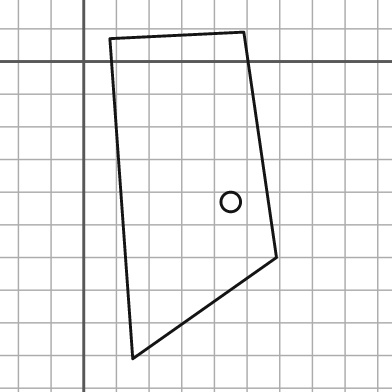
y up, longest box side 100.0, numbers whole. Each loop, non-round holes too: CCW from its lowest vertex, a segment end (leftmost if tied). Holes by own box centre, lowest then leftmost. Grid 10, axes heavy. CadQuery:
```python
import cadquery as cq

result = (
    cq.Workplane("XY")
    .moveTo(15.0, -91.0)
    .lineTo(59.0, -60.0)
    .lineTo(49.0, 9.0)
    .lineTo(8.0, 7.0)
    .close()
    .moveTo(45.0, -43.0)
    .circle(3.0)
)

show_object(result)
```